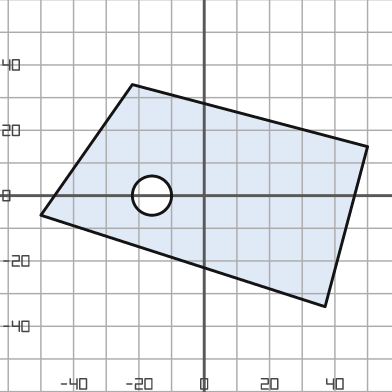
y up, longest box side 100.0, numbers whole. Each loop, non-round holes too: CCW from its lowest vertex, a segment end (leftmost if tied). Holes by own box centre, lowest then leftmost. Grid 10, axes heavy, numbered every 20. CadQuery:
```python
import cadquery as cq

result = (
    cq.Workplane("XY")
    .moveTo(37.0, -34.0)
    .lineTo(50.0, 15.0)
    .lineTo(-22.0, 34.0)
    .lineTo(-50.0, -6.0)
    .close()
    .moveTo(-16.0, 0.0)
    .circle(6.0)
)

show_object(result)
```